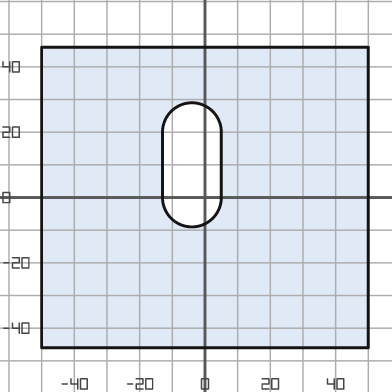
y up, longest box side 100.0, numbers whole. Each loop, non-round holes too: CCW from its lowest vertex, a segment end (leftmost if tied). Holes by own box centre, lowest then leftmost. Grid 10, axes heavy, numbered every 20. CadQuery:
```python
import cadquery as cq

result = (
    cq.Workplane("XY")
    .moveTo(-50.0, -46.0)
    .lineTo(50.0, -46.0)
    .lineTo(50.0, 46.0)
    .lineTo(-50.0, 46.0)
    .close()
    .moveTo(-13.0, 0.0)
    .threePointArc((-4.0, -9.0), (5.0, 0.0))
    .lineTo(5.0, 20.0)
    .threePointArc((-4.0, 29.0), (-13.0, 20.0))
    .close()
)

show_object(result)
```